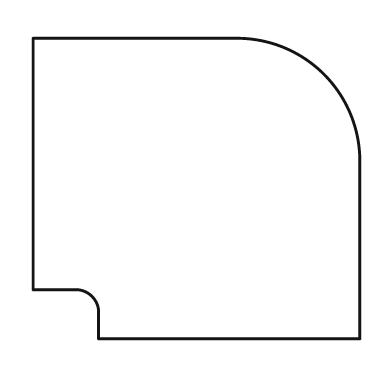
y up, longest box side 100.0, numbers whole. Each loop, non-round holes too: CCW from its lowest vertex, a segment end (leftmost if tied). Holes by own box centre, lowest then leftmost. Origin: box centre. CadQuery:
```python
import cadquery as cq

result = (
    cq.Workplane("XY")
    .moveTo(-30.0, -46.0)
    .lineTo(50.0, -46.0)
    .lineTo(50.0, 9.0)
    .threePointArc((39.0, 35.0), (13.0, 46.0))
    .lineTo(-50.0, 46.0)
    .lineTo(-50.0, -31.0)
    .lineTo(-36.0, -31.0)
    .threePointArc((-32.0, -33.0), (-30.0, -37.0))
    .close()
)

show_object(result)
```